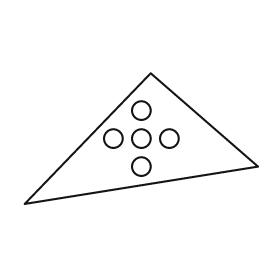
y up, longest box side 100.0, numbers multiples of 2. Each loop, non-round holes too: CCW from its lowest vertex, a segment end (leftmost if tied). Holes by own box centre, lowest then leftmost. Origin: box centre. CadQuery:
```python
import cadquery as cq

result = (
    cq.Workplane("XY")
    .moveTo(-50.0, -28.0)
    .lineTo(50.0, -12.0)
    .lineTo(4.0, 28.0)
    .close()
    .moveTo(0.0, -12.0)
    .circle(4.0)
    .moveTo(-12.0, 0.0)
    .circle(4.0)
    .moveTo(0.0, 0.0)
    .circle(4.0)
    .moveTo(12.0, 0.0)
    .circle(4.0)
    .moveTo(0.0, 12.0)
    .circle(4.0)
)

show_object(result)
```